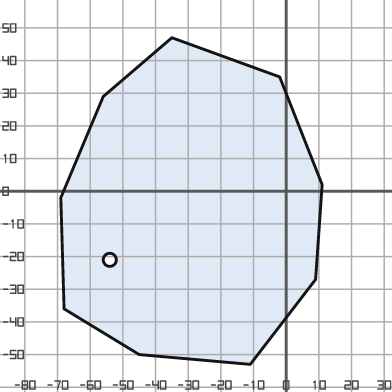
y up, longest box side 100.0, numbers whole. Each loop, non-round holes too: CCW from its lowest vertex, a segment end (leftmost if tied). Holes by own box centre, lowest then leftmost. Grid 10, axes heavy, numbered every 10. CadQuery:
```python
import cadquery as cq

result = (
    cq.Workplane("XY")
    .moveTo(-11.0, -53.0)
    .lineTo(9.0, -27.0)
    .lineTo(11.0, 2.0)
    .lineTo(-2.0, 35.0)
    .lineTo(-35.0, 47.0)
    .lineTo(-56.0, 29.0)
    .lineTo(-69.0, -2.0)
    .lineTo(-68.0, -36.0)
    .lineTo(-45.0, -50.0)
    .close()
    .moveTo(-54.0, -21.0)
    .circle(2.0)
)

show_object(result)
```